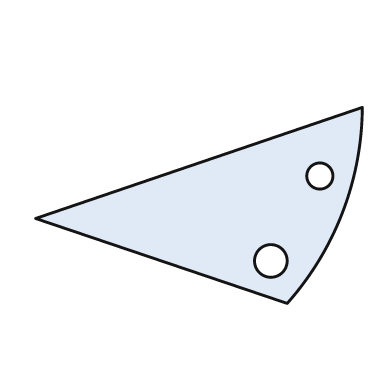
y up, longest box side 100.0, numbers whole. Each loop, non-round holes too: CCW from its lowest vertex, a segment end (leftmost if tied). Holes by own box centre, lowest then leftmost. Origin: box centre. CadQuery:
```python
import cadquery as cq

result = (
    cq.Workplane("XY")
    .moveTo(27.0, -30.0)
    .threePointArc((44.0, -2.0), (50.0, 30.0))
    .lineTo(-50.0, -4.0)
    .close()
    .moveTo(22.0, -17.0)
    .circle(5.0)
    .moveTo(37.0, 9.0)
    .circle(4.0)
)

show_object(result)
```